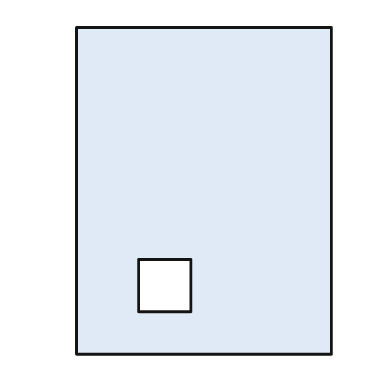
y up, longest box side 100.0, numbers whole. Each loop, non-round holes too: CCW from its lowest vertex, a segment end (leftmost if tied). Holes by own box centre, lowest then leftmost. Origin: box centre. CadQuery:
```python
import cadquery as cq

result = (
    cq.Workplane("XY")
    .moveTo(-39.0, -50.0)
    .lineTo(39.0, -50.0)
    .lineTo(39.0, 50.0)
    .lineTo(-39.0, 50.0)
    .close()
    .moveTo(-20.0, -37.0)
    .lineTo(-4.0, -37.0)
    .lineTo(-4.0, -21.0)
    .lineTo(-20.0, -21.0)
    .close()
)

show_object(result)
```